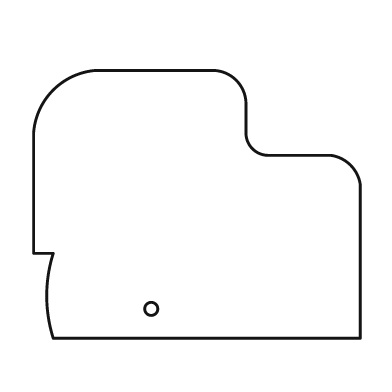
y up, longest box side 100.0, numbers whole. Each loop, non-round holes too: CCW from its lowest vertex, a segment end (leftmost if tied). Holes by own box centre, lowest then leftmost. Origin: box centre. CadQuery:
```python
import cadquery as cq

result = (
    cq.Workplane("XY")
    .moveTo(-44.0, -41.0)
    .lineTo(50.0, -41.0)
    .lineTo(50.0, 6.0)
    .threePointArc((47.0, 12.0), (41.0, 15.0))
    .lineTo(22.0, 15.0)
    .threePointArc((17.0, 17.0), (15.0, 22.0))
    .lineTo(15.0, 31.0)
    .threePointArc((12.0, 38.0), (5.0, 41.0))
    .lineTo(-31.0, 41.0)
    .threePointArc((-44.0, 35.0), (-50.0, 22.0))
    .lineTo(-50.0, -15.0)
    .lineTo(-44.0, -15.0)
    .threePointArc((-46.0, -28.0), (-44.0, -41.0))
    .close()
    .moveTo(-14.0, -32.0)
    .circle(2.0)
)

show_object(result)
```